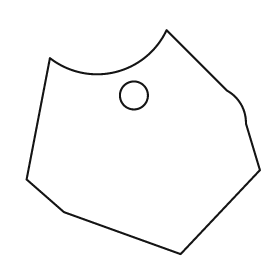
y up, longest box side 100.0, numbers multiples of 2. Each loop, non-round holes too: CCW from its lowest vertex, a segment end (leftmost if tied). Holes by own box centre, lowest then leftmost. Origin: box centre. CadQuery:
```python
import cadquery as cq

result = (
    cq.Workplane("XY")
    .moveTo(16.0, -48.0)
    .lineTo(50.0, -12.0)
    .lineTo(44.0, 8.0)
    .threePointArc((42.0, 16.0), (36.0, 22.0))
    .lineTo(10.0, 48.0)
    .threePointArc((-12.0, 30.0), (-40.0, 36.0))
    .lineTo(-50.0, -16.0)
    .lineTo(-34.0, -30.0)
    .close()
    .moveTo(-4.0, 20.0)
    .circle(6.0)
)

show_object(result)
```